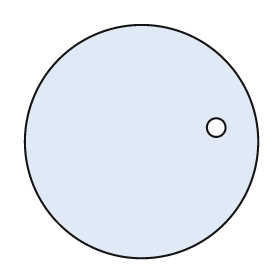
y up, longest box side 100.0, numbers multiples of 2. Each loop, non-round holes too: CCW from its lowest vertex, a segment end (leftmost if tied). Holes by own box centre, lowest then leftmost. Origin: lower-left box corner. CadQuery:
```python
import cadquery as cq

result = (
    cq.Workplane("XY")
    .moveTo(50.0, 50.0)
    .circle(50.0)
    .moveTo(82.0, 56.0)
    .circle(4.0)
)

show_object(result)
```